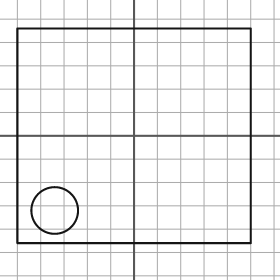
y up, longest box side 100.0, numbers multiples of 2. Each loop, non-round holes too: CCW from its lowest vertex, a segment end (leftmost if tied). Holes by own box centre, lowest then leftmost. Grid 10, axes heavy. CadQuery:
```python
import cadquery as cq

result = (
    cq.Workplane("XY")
    .moveTo(-50.0, -46.0)
    .lineTo(50.0, -46.0)
    .lineTo(50.0, 46.0)
    .lineTo(-50.0, 46.0)
    .close()
    .moveTo(-34.0, -32.0)
    .circle(10.0)
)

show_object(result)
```